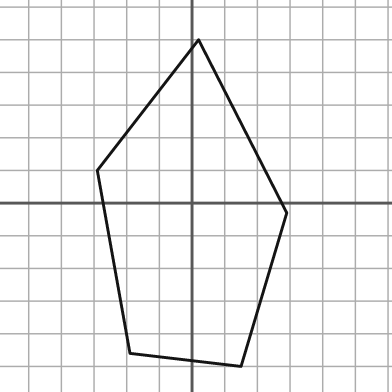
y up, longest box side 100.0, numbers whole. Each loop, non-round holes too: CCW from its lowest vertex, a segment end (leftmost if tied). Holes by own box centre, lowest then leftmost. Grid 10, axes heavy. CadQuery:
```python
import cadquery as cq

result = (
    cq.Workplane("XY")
    .moveTo(15.0, -50.0)
    .lineTo(29.0, -3.0)
    .lineTo(2.0, 50.0)
    .lineTo(-29.0, 10.0)
    .lineTo(-19.0, -46.0)
    .close()
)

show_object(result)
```